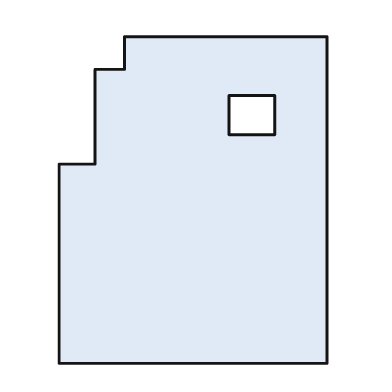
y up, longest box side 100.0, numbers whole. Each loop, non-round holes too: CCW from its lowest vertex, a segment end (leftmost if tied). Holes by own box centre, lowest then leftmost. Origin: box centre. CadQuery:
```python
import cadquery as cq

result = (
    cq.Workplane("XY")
    .moveTo(-41.0, -50.0)
    .lineTo(41.0, -50.0)
    .lineTo(41.0, 50.0)
    .lineTo(-21.0, 50.0)
    .lineTo(-21.0, 40.0)
    .lineTo(-30.0, 40.0)
    .lineTo(-30.0, 11.0)
    .lineTo(-41.0, 11.0)
    .close()
    .moveTo(11.0, 20.0)
    .lineTo(25.0, 20.0)
    .lineTo(25.0, 32.0)
    .lineTo(11.0, 32.0)
    .close()
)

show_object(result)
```